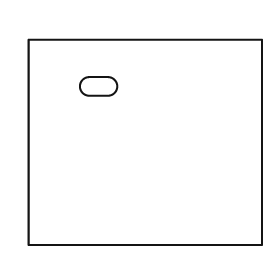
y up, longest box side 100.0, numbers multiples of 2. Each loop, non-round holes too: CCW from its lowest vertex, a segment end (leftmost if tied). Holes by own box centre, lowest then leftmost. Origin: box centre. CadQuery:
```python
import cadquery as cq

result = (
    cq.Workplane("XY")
    .moveTo(-50.0, -44.0)
    .lineTo(50.0, -44.0)
    .lineTo(50.0, 44.0)
    .lineTo(-50.0, 44.0)
    .close()
    .moveTo(-24.0, 20.0)
    .lineTo(-16.0, 20.0)
    .threePointArc((-12.0, 24.0), (-16.0, 28.0))
    .lineTo(-24.0, 28.0)
    .threePointArc((-28.0, 24.0), (-24.0, 20.0))
    .close()
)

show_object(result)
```